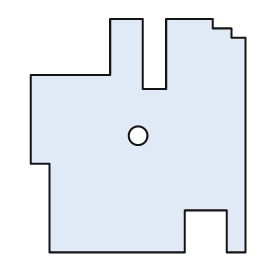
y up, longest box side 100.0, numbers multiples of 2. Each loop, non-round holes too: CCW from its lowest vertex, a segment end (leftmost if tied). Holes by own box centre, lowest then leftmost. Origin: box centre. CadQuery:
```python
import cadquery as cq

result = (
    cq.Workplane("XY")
    .moveTo(-38.0, -50.0)
    .lineTo(20.0, -50.0)
    .lineTo(20.0, -32.0)
    .lineTo(38.0, -32.0)
    .lineTo(38.0, -50.0)
    .lineTo(46.0, -50.0)
    .lineTo(46.0, 42.0)
    .lineTo(40.0, 42.0)
    .lineTo(40.0, 46.0)
    .lineTo(32.0, 46.0)
    .lineTo(32.0, 50.0)
    .lineTo(12.0, 50.0)
    .lineTo(12.0, 20.0)
    .lineTo(2.0, 20.0)
    .lineTo(2.0, 50.0)
    .lineTo(-12.0, 50.0)
    .lineTo(-12.0, 26.0)
    .lineTo(-46.0, 26.0)
    .lineTo(-46.0, -12.0)
    .lineTo(-38.0, -12.0)
    .close()
    .moveTo(0.0, 0.0)
    .circle(4.0)
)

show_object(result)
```